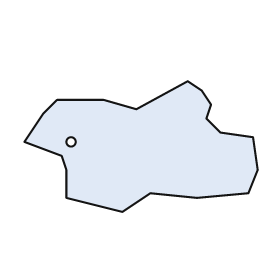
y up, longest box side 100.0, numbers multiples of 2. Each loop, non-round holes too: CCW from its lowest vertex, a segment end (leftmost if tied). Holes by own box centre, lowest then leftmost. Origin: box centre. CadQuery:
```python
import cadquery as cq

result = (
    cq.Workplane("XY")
    .moveTo(-8.0, -28.0)
    .lineTo(4.0, -20.0)
    .lineTo(24.0, -22.0)
    .lineTo(46.0, -20.0)
    .lineTo(50.0, -10.0)
    .lineTo(48.0, 4.0)
    .lineTo(34.0, 6.0)
    .lineTo(28.0, 12.0)
    .lineTo(30.0, 18.0)
    .lineTo(26.0, 24.0)
    .lineTo(20.0, 28.0)
    .lineTo(-2.0, 16.0)
    .lineTo(-16.0, 20.0)
    .lineTo(-36.0, 20.0)
    .lineTo(-42.0, 14.0)
    .lineTo(-50.0, 2.0)
    .lineTo(-34.0, -4.0)
    .lineTo(-32.0, -10.0)
    .lineTo(-32.0, -22.0)
    .close()
    .moveTo(-30.0, 2.0)
    .circle(2.0)
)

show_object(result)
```